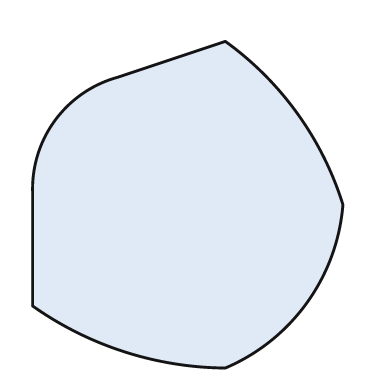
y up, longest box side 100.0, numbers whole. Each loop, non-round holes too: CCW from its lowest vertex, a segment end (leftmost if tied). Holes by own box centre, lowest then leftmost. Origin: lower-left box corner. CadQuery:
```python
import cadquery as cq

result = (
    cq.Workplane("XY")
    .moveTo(59.0, 0.0)
    .threePointArc((84.0, 20.0), (95.0, 50.0))
    .threePointArc((81.0, 78.0), (59.0, 100.0))
    .lineTo(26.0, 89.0)
    .threePointArc((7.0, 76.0), (0.0, 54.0))
    .lineTo(0.0, 19.0)
    .threePointArc((28.0, 5.0), (59.0, 0.0))
    .close()
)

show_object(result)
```